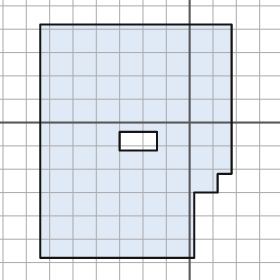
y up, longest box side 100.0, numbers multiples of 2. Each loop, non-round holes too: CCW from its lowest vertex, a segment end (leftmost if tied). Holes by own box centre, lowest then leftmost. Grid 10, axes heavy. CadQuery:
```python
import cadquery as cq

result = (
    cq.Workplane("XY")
    .moveTo(-64.0, -58.0)
    .lineTo(2.0, -58.0)
    .lineTo(2.0, -30.0)
    .lineTo(12.0, -30.0)
    .lineTo(12.0, -22.0)
    .lineTo(18.0, -22.0)
    .lineTo(18.0, 42.0)
    .lineTo(-64.0, 42.0)
    .close()
    .moveTo(-30.0, -12.0)
    .lineTo(-14.0, -12.0)
    .lineTo(-14.0, -4.0)
    .lineTo(-30.0, -4.0)
    .close()
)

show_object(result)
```